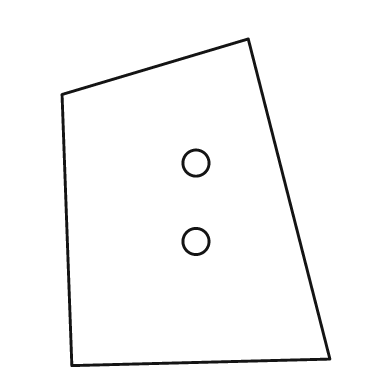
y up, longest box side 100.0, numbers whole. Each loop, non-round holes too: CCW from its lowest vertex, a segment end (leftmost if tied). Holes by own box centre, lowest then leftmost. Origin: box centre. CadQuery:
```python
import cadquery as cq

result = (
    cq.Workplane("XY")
    .moveTo(-38.0, -50.0)
    .lineTo(41.0, -48.0)
    .lineTo(16.0, 50.0)
    .lineTo(-41.0, 33.0)
    .close()
    .moveTo(0.0, -12.0)
    .circle(4.0)
    .moveTo(0.0, 12.0)
    .circle(4.0)
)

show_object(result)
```